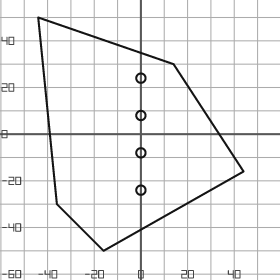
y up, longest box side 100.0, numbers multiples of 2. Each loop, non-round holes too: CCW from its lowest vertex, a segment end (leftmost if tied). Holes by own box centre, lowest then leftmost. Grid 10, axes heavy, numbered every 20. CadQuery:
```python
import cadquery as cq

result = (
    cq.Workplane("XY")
    .moveTo(-16.0, -50.0)
    .lineTo(44.0, -16.0)
    .lineTo(14.0, 30.0)
    .lineTo(-44.0, 50.0)
    .lineTo(-36.0, -30.0)
    .close()
    .moveTo(0.0, -24.0)
    .circle(2.0)
    .moveTo(0.0, -8.0)
    .circle(2.0)
    .moveTo(0.0, 8.0)
    .circle(2.0)
    .moveTo(0.0, 24.0)
    .circle(2.0)
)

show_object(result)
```